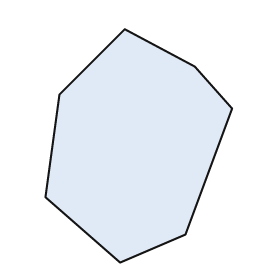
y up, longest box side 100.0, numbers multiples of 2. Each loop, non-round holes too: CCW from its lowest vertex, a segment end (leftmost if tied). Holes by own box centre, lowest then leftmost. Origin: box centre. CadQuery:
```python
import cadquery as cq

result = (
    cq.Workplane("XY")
    .moveTo(-8.0, -50.0)
    .lineTo(20.0, -38.0)
    .lineTo(40.0, 16.0)
    .lineTo(24.0, 34.0)
    .lineTo(-6.0, 50.0)
    .lineTo(-34.0, 22.0)
    .lineTo(-40.0, -22.0)
    .close()
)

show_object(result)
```